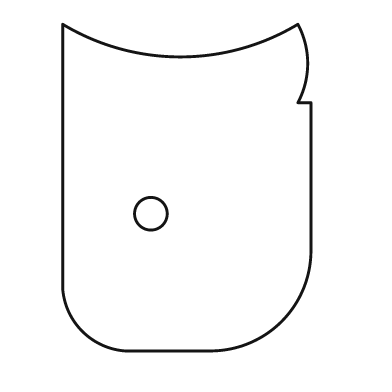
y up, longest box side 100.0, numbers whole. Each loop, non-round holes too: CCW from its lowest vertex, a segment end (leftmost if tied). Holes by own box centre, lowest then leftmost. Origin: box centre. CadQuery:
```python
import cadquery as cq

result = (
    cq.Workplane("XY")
    .moveTo(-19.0, -50.0)
    .lineTo(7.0, -50.0)
    .threePointArc((29.0, -41.0), (38.0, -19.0))
    .lineTo(38.0, 26.0)
    .lineTo(34.0, 26.0)
    .threePointArc((37.0, 38.0), (34.0, 50.0))
    .threePointArc((-2.0, 40.0), (-38.0, 50.0))
    .lineTo(-38.0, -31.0)
    .threePointArc((-32.0, -44.0), (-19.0, -50.0))
    .close()
    .moveTo(-11.0, -8.0)
    .circle(5.0)
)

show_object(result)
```